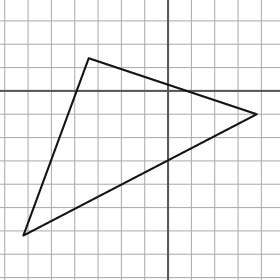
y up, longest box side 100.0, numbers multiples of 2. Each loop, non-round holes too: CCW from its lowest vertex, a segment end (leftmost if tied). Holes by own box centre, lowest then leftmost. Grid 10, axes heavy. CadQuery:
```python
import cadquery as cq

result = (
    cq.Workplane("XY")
    .moveTo(-62.0, -62.0)
    .lineTo(38.0, -10.0)
    .lineTo(-34.0, 14.0)
    .close()
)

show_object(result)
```